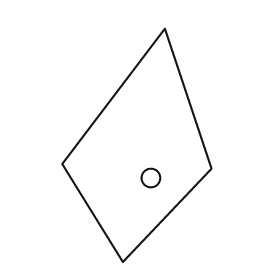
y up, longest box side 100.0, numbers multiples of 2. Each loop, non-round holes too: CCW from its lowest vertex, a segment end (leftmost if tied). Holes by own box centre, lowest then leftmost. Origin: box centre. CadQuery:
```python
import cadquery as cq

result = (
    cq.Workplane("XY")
    .moveTo(-6.0, -50.0)
    .lineTo(32.0, -10.0)
    .lineTo(12.0, 50.0)
    .lineTo(-32.0, -8.0)
    .close()
    .moveTo(6.0, -14.0)
    .circle(4.0)
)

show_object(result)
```